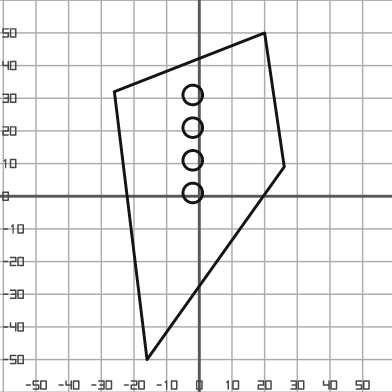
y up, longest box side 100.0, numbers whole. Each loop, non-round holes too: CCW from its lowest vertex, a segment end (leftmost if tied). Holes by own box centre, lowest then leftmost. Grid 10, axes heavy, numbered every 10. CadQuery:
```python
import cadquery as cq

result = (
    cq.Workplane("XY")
    .moveTo(-16.0, -50.0)
    .lineTo(26.0, 9.0)
    .lineTo(20.0, 50.0)
    .lineTo(-26.0, 32.0)
    .close()
    .moveTo(-2.0, 1.0)
    .circle(3.0)
    .moveTo(-2.0, 11.0)
    .circle(3.0)
    .moveTo(-2.0, 21.0)
    .circle(3.0)
    .moveTo(-2.0, 31.0)
    .circle(3.0)
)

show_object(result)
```